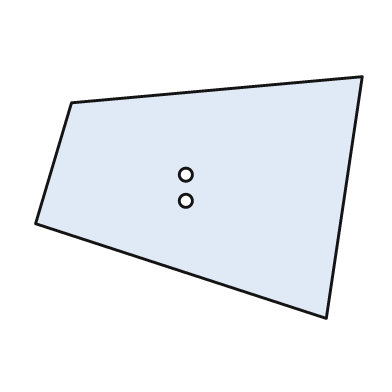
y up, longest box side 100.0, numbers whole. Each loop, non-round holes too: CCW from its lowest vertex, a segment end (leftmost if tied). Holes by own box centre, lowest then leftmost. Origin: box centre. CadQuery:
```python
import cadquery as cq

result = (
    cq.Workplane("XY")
    .moveTo(39.0, -37.0)
    .lineTo(50.0, 37.0)
    .lineTo(-39.0, 29.0)
    .lineTo(-50.0, -8.0)
    .close()
    .moveTo(-4.0, -1.0)
    .circle(2.0)
    .moveTo(-4.0, 7.0)
    .circle(2.0)
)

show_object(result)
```